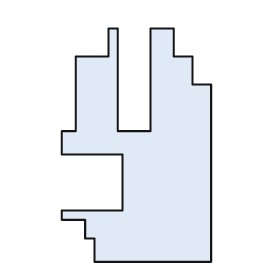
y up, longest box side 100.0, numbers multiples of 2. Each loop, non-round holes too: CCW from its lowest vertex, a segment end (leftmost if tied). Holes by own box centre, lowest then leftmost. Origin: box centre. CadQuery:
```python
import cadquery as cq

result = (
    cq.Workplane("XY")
    .moveTo(-18.0, -50.0)
    .lineTo(32.0, -50.0)
    .lineTo(32.0, 26.0)
    .lineTo(24.0, 26.0)
    .lineTo(24.0, 38.0)
    .lineTo(16.0, 38.0)
    .lineTo(16.0, 50.0)
    .lineTo(6.0, 50.0)
    .lineTo(6.0, 6.0)
    .lineTo(-8.0, 6.0)
    .lineTo(-8.0, 50.0)
    .lineTo(-12.0, 50.0)
    .lineTo(-12.0, 38.0)
    .lineTo(-26.0, 38.0)
    .lineTo(-26.0, 6.0)
    .lineTo(-32.0, 6.0)
    .lineTo(-32.0, -4.0)
    .lineTo(-6.0, -4.0)
    .lineTo(-6.0, -28.0)
    .lineTo(-32.0, -28.0)
    .lineTo(-32.0, -32.0)
    .lineTo(-22.0, -32.0)
    .lineTo(-22.0, -40.0)
    .lineTo(-18.0, -40.0)
    .close()
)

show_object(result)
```